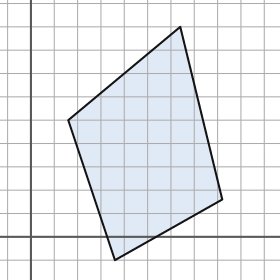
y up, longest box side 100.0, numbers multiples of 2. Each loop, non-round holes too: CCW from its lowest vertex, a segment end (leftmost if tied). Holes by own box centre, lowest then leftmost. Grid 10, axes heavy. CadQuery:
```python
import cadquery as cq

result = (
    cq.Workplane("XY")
    .moveTo(36.0, -10.0)
    .lineTo(82.0, 16.0)
    .lineTo(64.0, 90.0)
    .lineTo(16.0, 50.0)
    .close()
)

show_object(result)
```